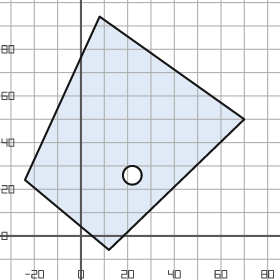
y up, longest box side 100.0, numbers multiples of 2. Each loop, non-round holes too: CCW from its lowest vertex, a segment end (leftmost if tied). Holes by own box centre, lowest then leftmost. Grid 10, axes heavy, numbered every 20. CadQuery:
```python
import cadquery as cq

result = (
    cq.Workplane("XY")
    .moveTo(12.0, -6.0)
    .lineTo(70.0, 50.0)
    .lineTo(8.0, 94.0)
    .lineTo(-24.0, 24.0)
    .close()
    .moveTo(22.0, 26.0)
    .circle(4.0)
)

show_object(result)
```